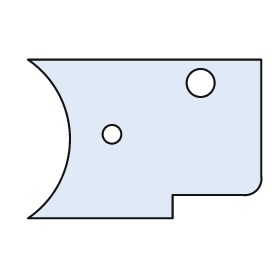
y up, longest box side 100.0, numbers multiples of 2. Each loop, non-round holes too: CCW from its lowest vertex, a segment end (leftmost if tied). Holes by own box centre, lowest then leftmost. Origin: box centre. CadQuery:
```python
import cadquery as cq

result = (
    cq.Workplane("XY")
    .moveTo(-50.0, -34.0)
    .lineTo(12.0, -34.0)
    .lineTo(12.0, -24.0)
    .lineTo(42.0, -24.0)
    .threePointArc((48.0, -22.0), (50.0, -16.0))
    .lineTo(50.0, 34.0)
    .lineTo(-50.0, 34.0)
    .threePointArc((-32.0, 0.0), (-50.0, -34.0))
    .close()
    .moveTo(-14.0, 2.0)
    .circle(4.0)
    .moveTo(24.0, 24.0)
    .circle(6.0)
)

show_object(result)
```